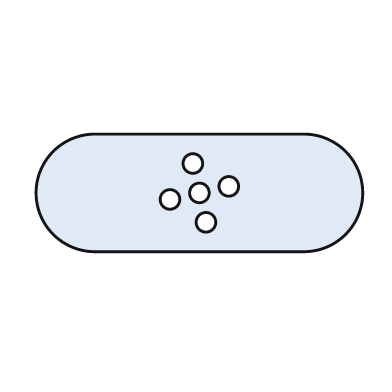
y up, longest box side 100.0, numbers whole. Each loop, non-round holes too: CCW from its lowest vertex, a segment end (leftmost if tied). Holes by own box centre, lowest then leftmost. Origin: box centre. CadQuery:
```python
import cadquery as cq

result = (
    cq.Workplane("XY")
    .moveTo(-32.0, -18.0)
    .lineTo(32.0, -18.0)
    .threePointArc((50.0, 0.0), (32.0, 18.0))
    .lineTo(-32.0, 18.0)
    .threePointArc((-50.0, 0.0), (-32.0, -18.0))
    .close()
    .moveTo(2.0, -9.0)
    .circle(3.0)
    .moveTo(-9.0, -2.0)
    .circle(3.0)
    .moveTo(0.0, 0.0)
    .circle(3.0)
    .moveTo(9.0, 2.0)
    .circle(3.0)
    .moveTo(-2.0, 9.0)
    .circle(3.0)
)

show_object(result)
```